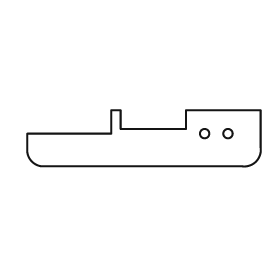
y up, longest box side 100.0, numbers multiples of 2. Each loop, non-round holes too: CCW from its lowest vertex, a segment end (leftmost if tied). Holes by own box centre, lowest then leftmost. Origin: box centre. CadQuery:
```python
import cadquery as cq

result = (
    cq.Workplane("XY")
    .moveTo(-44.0, -12.0)
    .lineTo(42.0, -12.0)
    .threePointArc((48.0, -10.0), (50.0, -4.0))
    .lineTo(50.0, 12.0)
    .lineTo(18.0, 12.0)
    .lineTo(18.0, 4.0)
    .lineTo(-10.0, 4.0)
    .lineTo(-10.0, 12.0)
    .lineTo(-14.0, 12.0)
    .lineTo(-14.0, 2.0)
    .lineTo(-50.0, 2.0)
    .lineTo(-50.0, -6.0)
    .threePointArc((-48.0, -10.0), (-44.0, -12.0))
    .close()
    .moveTo(26.0, 2.0)
    .circle(2.0)
    .moveTo(36.0, 2.0)
    .circle(2.0)
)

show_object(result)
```